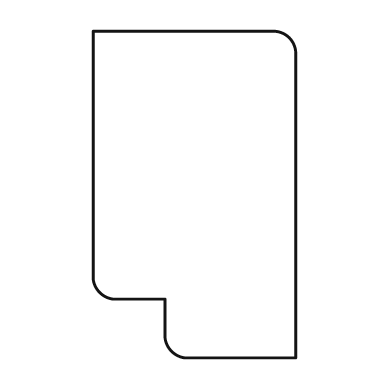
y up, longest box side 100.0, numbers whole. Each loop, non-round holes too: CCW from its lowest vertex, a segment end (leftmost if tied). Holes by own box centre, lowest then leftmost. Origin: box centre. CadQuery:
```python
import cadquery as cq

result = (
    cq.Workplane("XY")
    .moveTo(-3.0, -50.0)
    .lineTo(31.0, -50.0)
    .lineTo(31.0, 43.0)
    .threePointArc((29.0, 48.0), (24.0, 50.0))
    .lineTo(-31.0, 50.0)
    .lineTo(-31.0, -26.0)
    .threePointArc((-29.0, -30.0), (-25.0, -32.0))
    .lineTo(-9.0, -32.0)
    .lineTo(-9.0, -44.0)
    .threePointArc((-7.0, -48.0), (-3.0, -50.0))
    .close()
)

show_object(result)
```